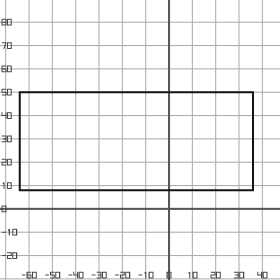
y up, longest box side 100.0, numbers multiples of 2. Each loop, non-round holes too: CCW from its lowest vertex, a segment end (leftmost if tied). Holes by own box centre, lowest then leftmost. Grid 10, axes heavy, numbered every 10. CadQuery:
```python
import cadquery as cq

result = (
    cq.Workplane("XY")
    .moveTo(-64.0, 8.0)
    .lineTo(36.0, 8.0)
    .lineTo(36.0, 50.0)
    .lineTo(-64.0, 50.0)
    .close()
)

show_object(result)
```